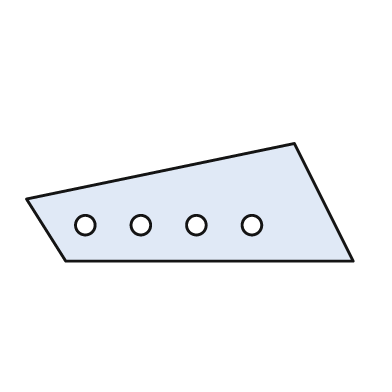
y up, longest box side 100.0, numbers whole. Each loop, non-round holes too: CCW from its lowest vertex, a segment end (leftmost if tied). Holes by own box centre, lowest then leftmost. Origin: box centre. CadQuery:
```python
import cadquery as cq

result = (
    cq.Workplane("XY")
    .moveTo(-38.0, -18.0)
    .lineTo(50.0, -18.0)
    .lineTo(32.0, 18.0)
    .lineTo(-50.0, 1.0)
    .close()
    .moveTo(-32.0, -7.0)
    .circle(3.0)
    .moveTo(-15.0, -7.0)
    .circle(3.0)
    .moveTo(2.0, -7.0)
    .circle(3.0)
    .moveTo(19.0, -7.0)
    .circle(3.0)
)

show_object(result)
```